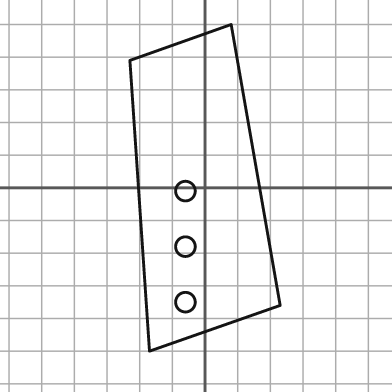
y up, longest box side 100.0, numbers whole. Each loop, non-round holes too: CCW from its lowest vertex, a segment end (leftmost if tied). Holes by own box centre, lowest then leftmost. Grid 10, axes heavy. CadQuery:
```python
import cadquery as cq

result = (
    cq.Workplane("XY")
    .moveTo(-17.0, -50.0)
    .lineTo(23.0, -36.0)
    .lineTo(8.0, 50.0)
    .lineTo(-23.0, 39.0)
    .close()
    .moveTo(-6.0, -35.0)
    .circle(3.0)
    .moveTo(-6.0, -18.0)
    .circle(3.0)
    .moveTo(-6.0, -1.0)
    .circle(3.0)
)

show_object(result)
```